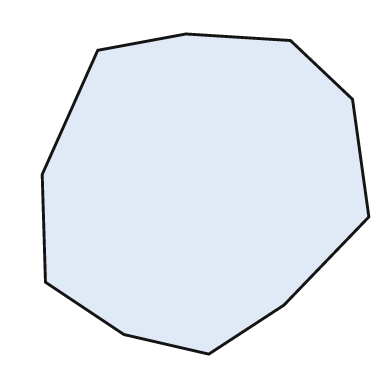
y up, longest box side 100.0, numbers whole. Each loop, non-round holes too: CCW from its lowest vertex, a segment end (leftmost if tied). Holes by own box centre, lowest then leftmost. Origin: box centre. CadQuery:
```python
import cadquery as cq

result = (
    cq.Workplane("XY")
    .moveTo(1.0, -49.0)
    .lineTo(24.0, -34.0)
    .lineTo(50.0, -7.0)
    .lineTo(45.0, 29.0)
    .lineTo(26.0, 47.0)
    .lineTo(-6.0, 49.0)
    .lineTo(-33.0, 44.0)
    .lineTo(-50.0, 6.0)
    .lineTo(-49.0, -27.0)
    .lineTo(-25.0, -43.0)
    .close()
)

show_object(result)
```